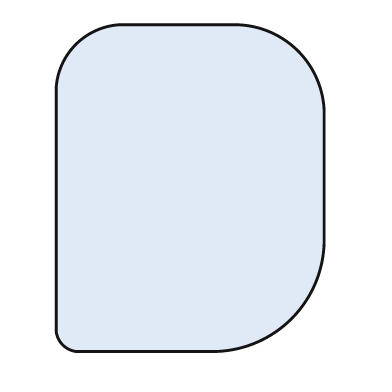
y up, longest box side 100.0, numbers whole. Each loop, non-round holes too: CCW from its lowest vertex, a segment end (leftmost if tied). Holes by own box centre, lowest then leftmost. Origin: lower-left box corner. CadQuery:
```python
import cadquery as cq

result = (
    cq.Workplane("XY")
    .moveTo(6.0, 0.0)
    .lineTo(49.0, 0.0)
    .threePointArc((72.0, 10.0), (82.0, 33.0))
    .lineTo(82.0, 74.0)
    .threePointArc((74.0, 92.0), (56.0, 100.0))
    .lineTo(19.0, 100.0)
    .threePointArc((6.0, 94.0), (0.0, 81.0))
    .lineTo(0.0, 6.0)
    .threePointArc((2.0, 2.0), (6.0, 0.0))
    .close()
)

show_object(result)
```